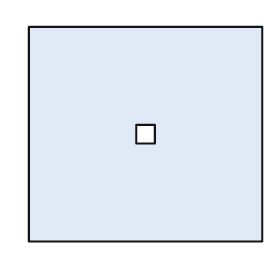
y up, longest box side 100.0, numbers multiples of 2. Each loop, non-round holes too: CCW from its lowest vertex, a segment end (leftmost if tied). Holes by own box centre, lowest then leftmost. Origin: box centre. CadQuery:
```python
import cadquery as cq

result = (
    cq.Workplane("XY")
    .moveTo(-50.0, -46.0)
    .lineTo(50.0, -46.0)
    .lineTo(50.0, 46.0)
    .lineTo(-50.0, 46.0)
    .close()
    .moveTo(-4.0, -4.0)
    .lineTo(4.0, -4.0)
    .lineTo(4.0, 4.0)
    .lineTo(-4.0, 4.0)
    .close()
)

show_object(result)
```